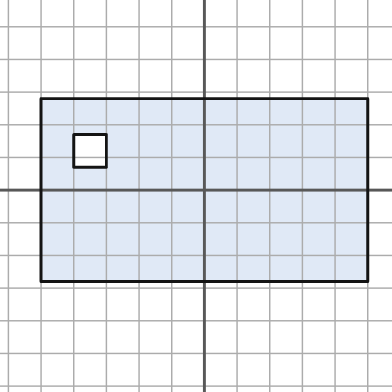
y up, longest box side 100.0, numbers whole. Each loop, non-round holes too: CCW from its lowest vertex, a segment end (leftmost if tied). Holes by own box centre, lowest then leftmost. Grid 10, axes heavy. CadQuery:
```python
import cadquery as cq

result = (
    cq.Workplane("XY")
    .moveTo(-50.0, -28.0)
    .lineTo(50.0, -28.0)
    .lineTo(50.0, 28.0)
    .lineTo(-50.0, 28.0)
    .close()
    .moveTo(-40.0, 7.0)
    .lineTo(-30.0, 7.0)
    .lineTo(-30.0, 17.0)
    .lineTo(-40.0, 17.0)
    .close()
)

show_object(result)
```